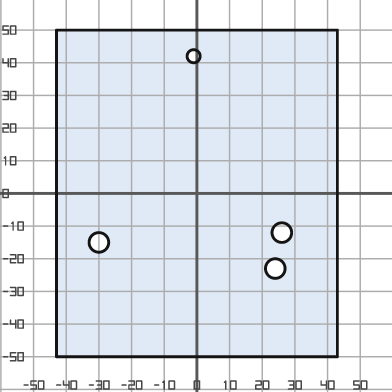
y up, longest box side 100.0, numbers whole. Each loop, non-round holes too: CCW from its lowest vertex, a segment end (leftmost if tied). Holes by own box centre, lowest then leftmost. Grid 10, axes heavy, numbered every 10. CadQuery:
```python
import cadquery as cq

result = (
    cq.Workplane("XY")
    .moveTo(-43.0, -50.0)
    .lineTo(43.0, -50.0)
    .lineTo(43.0, 50.0)
    .lineTo(-43.0, 50.0)
    .close()
    .moveTo(24.0, -23.0)
    .circle(3.0)
    .moveTo(-30.0, -15.0)
    .circle(3.0)
    .moveTo(26.0, -12.0)
    .circle(3.0)
    .moveTo(-1.0, 42.0)
    .circle(2.0)
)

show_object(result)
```